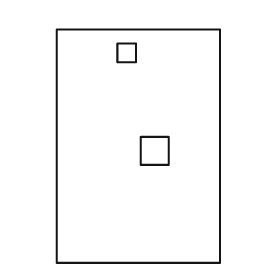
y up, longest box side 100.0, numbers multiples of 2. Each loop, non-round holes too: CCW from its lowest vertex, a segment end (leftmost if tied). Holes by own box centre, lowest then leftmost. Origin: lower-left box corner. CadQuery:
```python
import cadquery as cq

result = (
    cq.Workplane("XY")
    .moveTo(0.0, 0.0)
    .lineTo(70.0, 0.0)
    .lineTo(70.0, 100.0)
    .lineTo(0.0, 100.0)
    .close()
    .moveTo(36.0, 42.0)
    .lineTo(48.0, 42.0)
    .lineTo(48.0, 54.0)
    .lineTo(36.0, 54.0)
    .close()
    .moveTo(26.0, 86.0)
    .lineTo(34.0, 86.0)
    .lineTo(34.0, 94.0)
    .lineTo(26.0, 94.0)
    .close()
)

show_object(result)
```